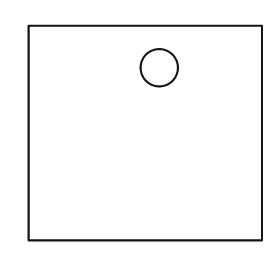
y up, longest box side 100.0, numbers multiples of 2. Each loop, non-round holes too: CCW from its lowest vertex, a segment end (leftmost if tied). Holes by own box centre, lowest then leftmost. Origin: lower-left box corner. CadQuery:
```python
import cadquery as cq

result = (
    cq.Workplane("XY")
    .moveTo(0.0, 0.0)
    .lineTo(100.0, 0.0)
    .lineTo(100.0, 92.0)
    .lineTo(0.0, 92.0)
    .close()
    .moveTo(56.0, 74.0)
    .circle(8.0)
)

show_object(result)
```